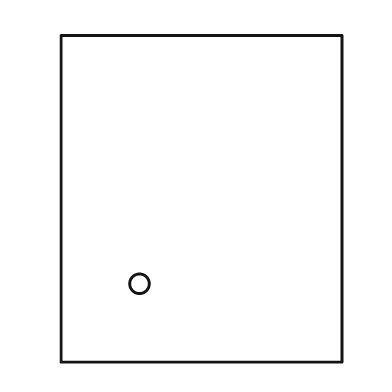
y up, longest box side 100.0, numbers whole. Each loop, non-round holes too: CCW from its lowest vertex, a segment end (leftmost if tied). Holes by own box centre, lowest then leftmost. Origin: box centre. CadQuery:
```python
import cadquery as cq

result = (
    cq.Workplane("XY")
    .moveTo(-43.0, -50.0)
    .lineTo(43.0, -50.0)
    .lineTo(43.0, 50.0)
    .lineTo(-43.0, 50.0)
    .close()
    .moveTo(-19.0, -26.0)
    .circle(3.0)
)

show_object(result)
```